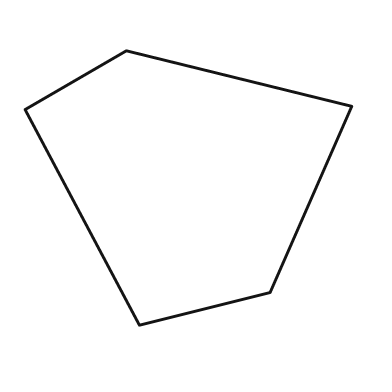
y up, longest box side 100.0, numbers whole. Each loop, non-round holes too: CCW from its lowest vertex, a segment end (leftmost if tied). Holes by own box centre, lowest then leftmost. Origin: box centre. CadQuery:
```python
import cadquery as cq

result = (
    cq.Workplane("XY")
    .moveTo(-15.0, -42.0)
    .lineTo(25.0, -32.0)
    .lineTo(50.0, 25.0)
    .lineTo(-19.0, 42.0)
    .lineTo(-50.0, 24.0)
    .close()
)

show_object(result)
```